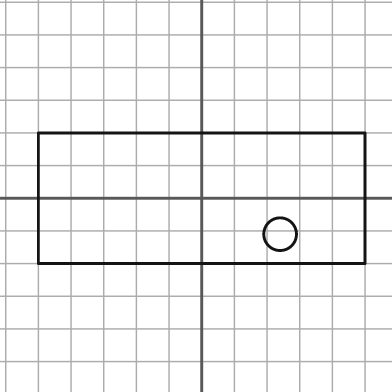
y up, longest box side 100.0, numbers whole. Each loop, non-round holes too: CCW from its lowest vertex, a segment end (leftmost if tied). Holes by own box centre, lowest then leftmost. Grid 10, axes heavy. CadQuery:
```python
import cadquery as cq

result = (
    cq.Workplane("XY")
    .moveTo(-50.0, -20.0)
    .lineTo(50.0, -20.0)
    .lineTo(50.0, 20.0)
    .lineTo(-50.0, 20.0)
    .close()
    .moveTo(24.0, -11.0)
    .circle(5.0)
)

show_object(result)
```